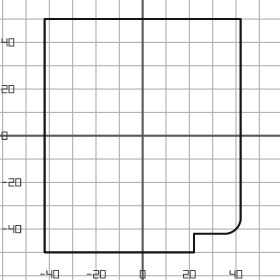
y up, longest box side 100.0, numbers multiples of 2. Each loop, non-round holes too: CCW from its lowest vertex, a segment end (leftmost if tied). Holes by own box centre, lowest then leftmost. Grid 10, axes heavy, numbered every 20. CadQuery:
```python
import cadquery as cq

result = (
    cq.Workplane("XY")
    .moveTo(-42.0, -50.0)
    .lineTo(22.0, -50.0)
    .lineTo(22.0, -42.0)
    .lineTo(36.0, -42.0)
    .threePointArc((40.0, -40.0), (42.0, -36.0))
    .lineTo(42.0, 50.0)
    .lineTo(-42.0, 50.0)
    .close()
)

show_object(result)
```